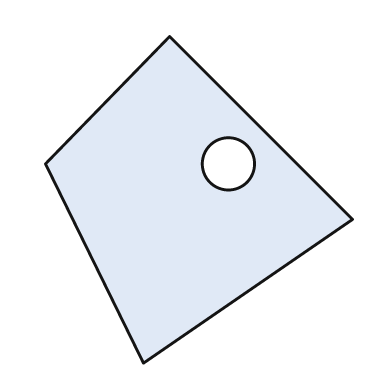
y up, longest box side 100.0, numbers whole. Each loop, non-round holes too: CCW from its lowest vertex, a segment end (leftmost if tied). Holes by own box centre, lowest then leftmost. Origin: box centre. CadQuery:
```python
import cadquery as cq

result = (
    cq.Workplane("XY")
    .moveTo(-17.0, -50.0)
    .lineTo(47.0, -6.0)
    .lineTo(-9.0, 50.0)
    .lineTo(-47.0, 11.0)
    .close()
    .moveTo(9.0, 11.0)
    .circle(8.0)
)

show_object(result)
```